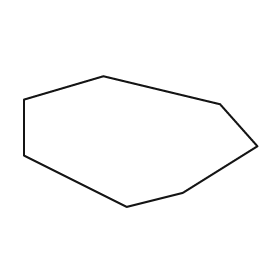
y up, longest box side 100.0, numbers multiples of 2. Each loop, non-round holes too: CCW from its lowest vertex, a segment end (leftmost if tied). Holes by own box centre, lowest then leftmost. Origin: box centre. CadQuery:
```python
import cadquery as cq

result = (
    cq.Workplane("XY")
    .moveTo(-6.0, -28.0)
    .lineTo(18.0, -22.0)
    .lineTo(50.0, -2.0)
    .lineTo(34.0, 16.0)
    .lineTo(-16.0, 28.0)
    .lineTo(-50.0, 18.0)
    .lineTo(-50.0, -6.0)
    .close()
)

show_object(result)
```